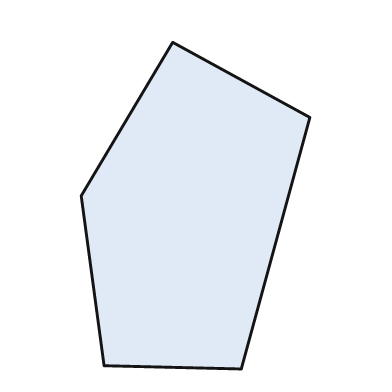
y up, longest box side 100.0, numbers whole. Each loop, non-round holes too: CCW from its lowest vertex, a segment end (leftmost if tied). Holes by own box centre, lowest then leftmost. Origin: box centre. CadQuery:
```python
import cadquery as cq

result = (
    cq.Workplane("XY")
    .moveTo(14.0, -50.0)
    .lineTo(35.0, 27.0)
    .lineTo(-7.0, 50.0)
    .lineTo(-35.0, 3.0)
    .lineTo(-28.0, -49.0)
    .close()
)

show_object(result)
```